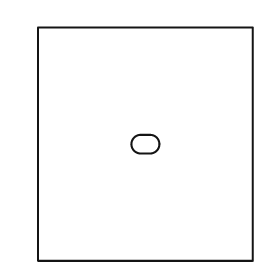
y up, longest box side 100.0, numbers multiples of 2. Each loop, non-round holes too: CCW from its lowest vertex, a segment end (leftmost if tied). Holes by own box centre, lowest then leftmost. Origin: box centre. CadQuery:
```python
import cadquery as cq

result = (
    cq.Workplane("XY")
    .moveTo(-46.0, -50.0)
    .lineTo(46.0, -50.0)
    .lineTo(46.0, 50.0)
    .lineTo(-46.0, 50.0)
    .close()
    .moveTo(-2.0, -4.0)
    .lineTo(2.0, -4.0)
    .threePointArc((6.0, 0.0), (2.0, 4.0))
    .lineTo(-2.0, 4.0)
    .threePointArc((-6.0, 0.0), (-2.0, -4.0))
    .close()
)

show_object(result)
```